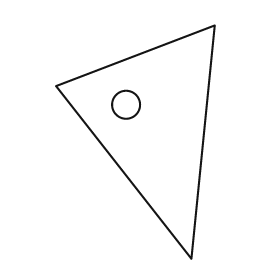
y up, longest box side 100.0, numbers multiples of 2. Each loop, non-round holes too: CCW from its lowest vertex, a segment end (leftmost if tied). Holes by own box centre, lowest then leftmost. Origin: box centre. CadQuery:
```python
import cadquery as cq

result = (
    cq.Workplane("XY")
    .moveTo(24.0, -50.0)
    .lineTo(34.0, 50.0)
    .lineTo(-34.0, 24.0)
    .close()
    .moveTo(-4.0, 16.0)
    .circle(6.0)
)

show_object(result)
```